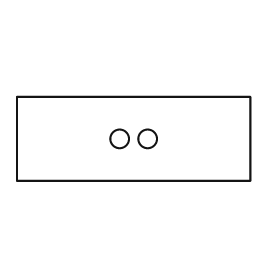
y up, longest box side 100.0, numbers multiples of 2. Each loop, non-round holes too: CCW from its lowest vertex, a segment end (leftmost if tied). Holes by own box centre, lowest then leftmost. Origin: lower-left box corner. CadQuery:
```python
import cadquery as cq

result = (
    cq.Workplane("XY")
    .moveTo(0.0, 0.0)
    .lineTo(100.0, 0.0)
    .lineTo(100.0, 36.0)
    .lineTo(0.0, 36.0)
    .close()
    .moveTo(44.0, 18.0)
    .circle(4.0)
    .moveTo(56.0, 18.0)
    .circle(4.0)
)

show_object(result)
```